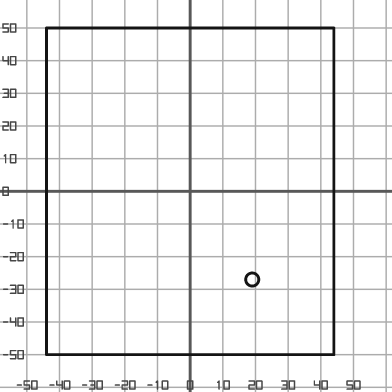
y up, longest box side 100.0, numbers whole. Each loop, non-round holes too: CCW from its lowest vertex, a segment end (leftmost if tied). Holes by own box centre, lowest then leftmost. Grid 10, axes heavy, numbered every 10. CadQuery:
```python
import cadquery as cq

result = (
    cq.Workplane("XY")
    .moveTo(-44.0, -50.0)
    .lineTo(44.0, -50.0)
    .lineTo(44.0, 50.0)
    .lineTo(-44.0, 50.0)
    .close()
    .moveTo(19.0, -27.0)
    .circle(2.0)
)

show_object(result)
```